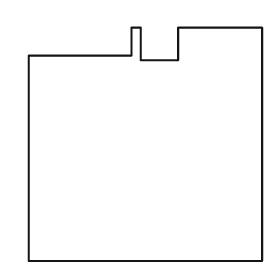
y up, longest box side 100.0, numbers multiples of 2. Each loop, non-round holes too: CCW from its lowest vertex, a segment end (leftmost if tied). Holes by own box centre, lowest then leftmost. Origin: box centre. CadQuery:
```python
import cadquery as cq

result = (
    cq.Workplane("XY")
    .moveTo(-50.0, -50.0)
    .lineTo(50.0, -50.0)
    .lineTo(50.0, 50.0)
    .lineTo(14.0, 50.0)
    .lineTo(14.0, 36.0)
    .lineTo(-2.0, 36.0)
    .lineTo(-2.0, 50.0)
    .lineTo(-6.0, 50.0)
    .lineTo(-6.0, 38.0)
    .lineTo(-50.0, 38.0)
    .close()
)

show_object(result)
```